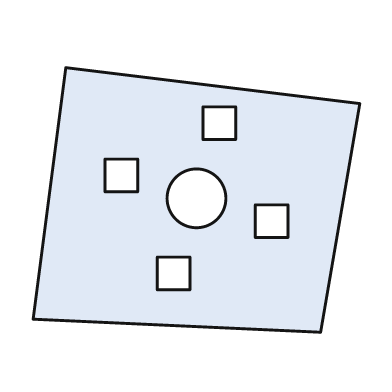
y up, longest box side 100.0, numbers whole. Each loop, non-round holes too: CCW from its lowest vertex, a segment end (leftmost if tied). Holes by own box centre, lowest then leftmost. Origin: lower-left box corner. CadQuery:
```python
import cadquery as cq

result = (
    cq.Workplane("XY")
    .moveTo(88.0, 0.0)
    .lineTo(100.0, 70.0)
    .lineTo(10.0, 81.0)
    .lineTo(0.0, 4.0)
    .close()
    .moveTo(38.0, 13.0)
    .lineTo(48.0, 13.0)
    .lineTo(48.0, 23.0)
    .lineTo(38.0, 23.0)
    .close()
    .moveTo(68.0, 29.0)
    .lineTo(78.0, 29.0)
    .lineTo(78.0, 39.0)
    .lineTo(68.0, 39.0)
    .close()
    .moveTo(50.0, 41.0)
    .circle(9.0)
    .moveTo(22.0, 43.0)
    .lineTo(32.0, 43.0)
    .lineTo(32.0, 53.0)
    .lineTo(22.0, 53.0)
    .close()
    .moveTo(52.0, 59.0)
    .lineTo(62.0, 59.0)
    .lineTo(62.0, 69.0)
    .lineTo(52.0, 69.0)
    .close()
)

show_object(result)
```